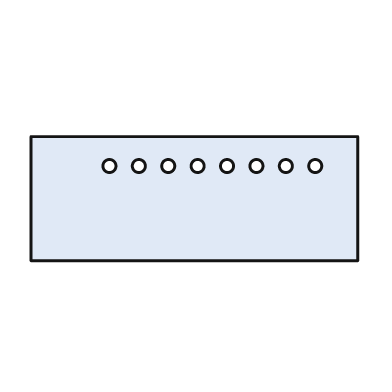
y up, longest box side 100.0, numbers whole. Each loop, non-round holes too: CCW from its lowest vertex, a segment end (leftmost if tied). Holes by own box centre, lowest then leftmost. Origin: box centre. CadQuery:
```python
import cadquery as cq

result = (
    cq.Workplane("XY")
    .moveTo(-50.0, -19.0)
    .lineTo(50.0, -19.0)
    .lineTo(50.0, 19.0)
    .lineTo(-50.0, 19.0)
    .close()
    .moveTo(-26.0, 10.0)
    .circle(2.0)
    .moveTo(-17.0, 10.0)
    .circle(2.0)
    .moveTo(-8.0, 10.0)
    .circle(2.0)
    .moveTo(1.0, 10.0)
    .circle(2.0)
    .moveTo(10.0, 10.0)
    .circle(2.0)
    .moveTo(19.0, 10.0)
    .circle(2.0)
    .moveTo(28.0, 10.0)
    .circle(2.0)
    .moveTo(37.0, 10.0)
    .circle(2.0)
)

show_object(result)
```